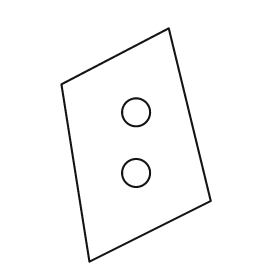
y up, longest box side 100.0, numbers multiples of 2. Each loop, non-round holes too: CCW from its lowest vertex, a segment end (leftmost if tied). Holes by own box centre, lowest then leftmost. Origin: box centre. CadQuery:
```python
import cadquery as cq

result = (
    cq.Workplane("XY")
    .moveTo(-20.0, -50.0)
    .lineTo(32.0, -24.0)
    .lineTo(14.0, 50.0)
    .lineTo(-32.0, 26.0)
    .close()
    .moveTo(0.0, -12.0)
    .circle(6.0)
    .moveTo(0.0, 14.0)
    .circle(6.0)
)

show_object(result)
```